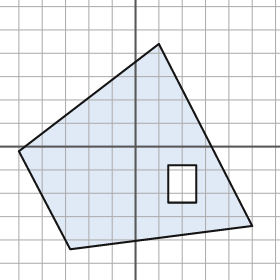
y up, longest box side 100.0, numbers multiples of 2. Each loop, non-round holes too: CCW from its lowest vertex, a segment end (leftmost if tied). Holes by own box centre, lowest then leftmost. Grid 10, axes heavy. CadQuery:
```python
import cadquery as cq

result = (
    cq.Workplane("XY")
    .moveTo(-28.0, -44.0)
    .lineTo(50.0, -34.0)
    .lineTo(10.0, 44.0)
    .lineTo(-50.0, -2.0)
    .close()
    .moveTo(14.0, -24.0)
    .lineTo(26.0, -24.0)
    .lineTo(26.0, -8.0)
    .lineTo(14.0, -8.0)
    .close()
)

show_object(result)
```